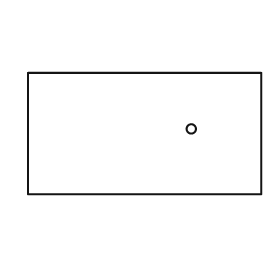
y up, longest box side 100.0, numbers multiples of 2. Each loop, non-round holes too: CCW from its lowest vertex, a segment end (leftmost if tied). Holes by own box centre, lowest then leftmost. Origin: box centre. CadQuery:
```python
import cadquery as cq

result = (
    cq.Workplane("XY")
    .moveTo(-50.0, -26.0)
    .lineTo(50.0, -26.0)
    .lineTo(50.0, 26.0)
    .lineTo(-50.0, 26.0)
    .close()
    .moveTo(20.0, 2.0)
    .circle(2.0)
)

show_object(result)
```